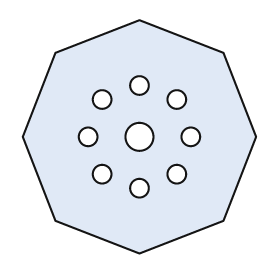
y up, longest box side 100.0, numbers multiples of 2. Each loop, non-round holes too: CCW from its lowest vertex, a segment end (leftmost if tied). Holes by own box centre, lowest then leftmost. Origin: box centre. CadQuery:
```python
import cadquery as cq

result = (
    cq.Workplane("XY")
    .moveTo(0.0, -50.0)
    .lineTo(36.0, -36.0)
    .lineTo(50.0, 0.0)
    .lineTo(36.0, 36.0)
    .lineTo(0.0, 50.0)
    .lineTo(-36.0, 36.0)
    .lineTo(-50.0, 0.0)
    .lineTo(-36.0, -36.0)
    .close()
    .moveTo(0.0, -22.0)
    .circle(4.0)
    .moveTo(-16.0, -16.0)
    .circle(4.0)
    .moveTo(16.0, -16.0)
    .circle(4.0)
    .moveTo(-22.0, 0.0)
    .circle(4.0)
    .moveTo(0.0, 0.0)
    .circle(6.0)
    .moveTo(22.0, 0.0)
    .circle(4.0)
    .moveTo(-16.0, 16.0)
    .circle(4.0)
    .moveTo(16.0, 16.0)
    .circle(4.0)
    .moveTo(0.0, 22.0)
    .circle(4.0)
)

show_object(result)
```